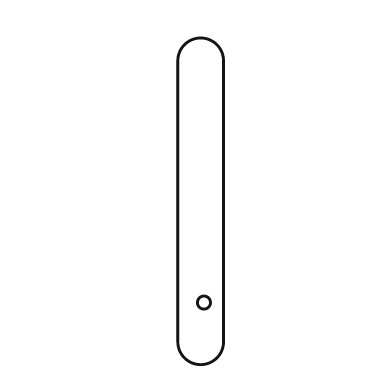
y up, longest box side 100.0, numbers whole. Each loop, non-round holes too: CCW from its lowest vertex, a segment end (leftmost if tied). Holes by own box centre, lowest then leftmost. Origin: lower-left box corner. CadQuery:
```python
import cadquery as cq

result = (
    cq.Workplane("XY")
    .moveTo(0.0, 7.0)
    .threePointArc((7.0, 0.0), (14.0, 7.0))
    .lineTo(14.0, 93.0)
    .threePointArc((7.0, 100.0), (0.0, 93.0))
    .close()
    .moveTo(8.0, 19.0)
    .circle(2.0)
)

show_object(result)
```